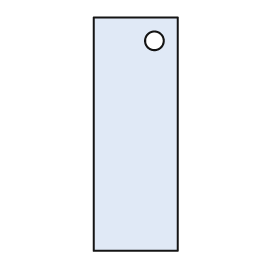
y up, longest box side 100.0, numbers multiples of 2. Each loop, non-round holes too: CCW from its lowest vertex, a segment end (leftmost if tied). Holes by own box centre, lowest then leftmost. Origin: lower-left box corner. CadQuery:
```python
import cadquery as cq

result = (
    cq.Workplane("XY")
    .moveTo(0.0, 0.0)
    .lineTo(36.0, 0.0)
    .lineTo(36.0, 100.0)
    .lineTo(0.0, 100.0)
    .close()
    .moveTo(26.0, 90.0)
    .circle(4.0)
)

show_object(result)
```